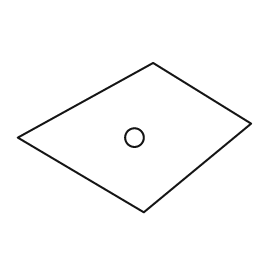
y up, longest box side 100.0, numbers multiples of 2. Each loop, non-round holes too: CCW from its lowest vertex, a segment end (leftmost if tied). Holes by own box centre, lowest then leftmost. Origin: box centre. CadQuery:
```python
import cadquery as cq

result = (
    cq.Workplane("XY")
    .moveTo(4.0, -32.0)
    .lineTo(50.0, 6.0)
    .lineTo(8.0, 32.0)
    .lineTo(-50.0, 0.0)
    .close()
    .moveTo(0.0, 0.0)
    .circle(4.0)
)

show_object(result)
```